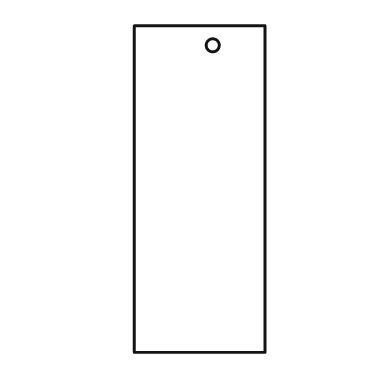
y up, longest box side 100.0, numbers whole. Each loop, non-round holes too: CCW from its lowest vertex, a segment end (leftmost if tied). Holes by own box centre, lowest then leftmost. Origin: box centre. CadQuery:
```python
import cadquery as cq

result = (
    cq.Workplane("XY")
    .moveTo(-20.0, -50.0)
    .lineTo(20.0, -50.0)
    .lineTo(20.0, 50.0)
    .lineTo(-20.0, 50.0)
    .close()
    .moveTo(4.0, 44.0)
    .circle(2.0)
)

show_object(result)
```